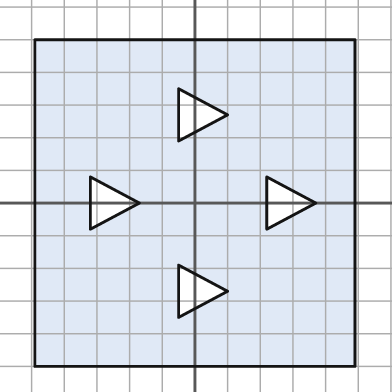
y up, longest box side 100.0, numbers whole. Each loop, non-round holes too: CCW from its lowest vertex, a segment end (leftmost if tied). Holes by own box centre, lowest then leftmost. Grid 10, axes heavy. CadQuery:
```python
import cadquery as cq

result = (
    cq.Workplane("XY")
    .moveTo(-49.0, -50.0)
    .lineTo(49.0, -50.0)
    .lineTo(49.0, 50.0)
    .lineTo(-49.0, 50.0)
    .close()
    .moveTo(-5.0, -35.0)
    .lineTo(10.0, -27.0)
    .lineTo(-5.0, -19.0)
    .close()
    .moveTo(-32.0, -8.0)
    .lineTo(-17.0, 0.0)
    .lineTo(-32.0, 8.0)
    .close()
    .moveTo(22.0, -8.0)
    .lineTo(37.0, 0.0)
    .lineTo(22.0, 8.0)
    .close()
    .moveTo(-5.0, 19.0)
    .lineTo(10.0, 27.0)
    .lineTo(-5.0, 35.0)
    .close()
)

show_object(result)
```